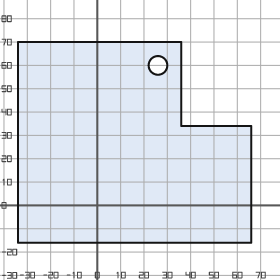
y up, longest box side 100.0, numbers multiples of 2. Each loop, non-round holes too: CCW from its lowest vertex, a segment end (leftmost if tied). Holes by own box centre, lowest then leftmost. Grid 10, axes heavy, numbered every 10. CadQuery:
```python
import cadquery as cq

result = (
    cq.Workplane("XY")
    .moveTo(-34.0, -16.0)
    .lineTo(66.0, -16.0)
    .lineTo(66.0, 34.0)
    .lineTo(36.0, 34.0)
    .lineTo(36.0, 70.0)
    .lineTo(-34.0, 70.0)
    .close()
    .moveTo(26.0, 60.0)
    .circle(4.0)
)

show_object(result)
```